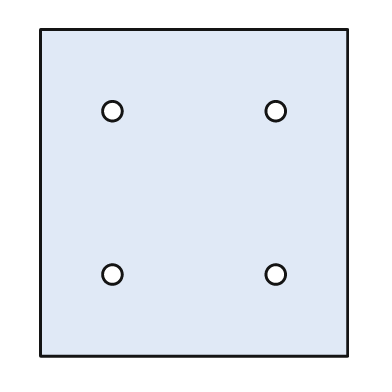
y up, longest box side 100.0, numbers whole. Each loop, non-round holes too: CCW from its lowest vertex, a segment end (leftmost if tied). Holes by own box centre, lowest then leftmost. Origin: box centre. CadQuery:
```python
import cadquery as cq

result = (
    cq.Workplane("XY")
    .moveTo(-47.0, -50.0)
    .lineTo(47.0, -50.0)
    .lineTo(47.0, 50.0)
    .lineTo(-47.0, 50.0)
    .close()
    .moveTo(-25.0, -25.0)
    .circle(3.0)
    .moveTo(25.0, -25.0)
    .circle(3.0)
    .moveTo(-25.0, 25.0)
    .circle(3.0)
    .moveTo(25.0, 25.0)
    .circle(3.0)
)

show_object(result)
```